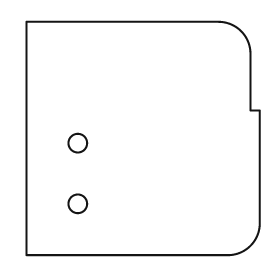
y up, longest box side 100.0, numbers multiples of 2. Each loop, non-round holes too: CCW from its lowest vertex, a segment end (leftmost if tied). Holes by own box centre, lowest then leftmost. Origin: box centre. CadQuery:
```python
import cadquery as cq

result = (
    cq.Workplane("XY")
    .moveTo(-50.0, -50.0)
    .lineTo(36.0, -50.0)
    .threePointArc((46.0, -46.0), (50.0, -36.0))
    .lineTo(50.0, 12.0)
    .lineTo(46.0, 12.0)
    .lineTo(46.0, 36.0)
    .threePointArc((42.0, 46.0), (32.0, 50.0))
    .lineTo(-50.0, 50.0)
    .close()
    .moveTo(-28.0, -28.0)
    .circle(4.0)
    .moveTo(-28.0, -2.0)
    .circle(4.0)
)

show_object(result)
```